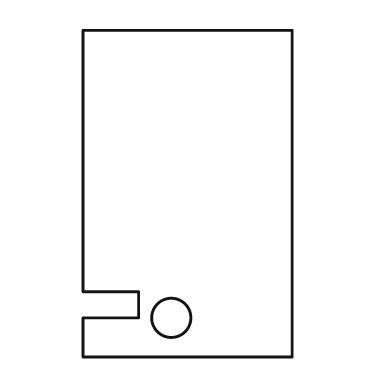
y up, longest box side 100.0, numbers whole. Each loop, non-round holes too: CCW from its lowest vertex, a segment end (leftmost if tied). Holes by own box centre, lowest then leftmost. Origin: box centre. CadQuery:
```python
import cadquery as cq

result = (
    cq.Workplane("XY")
    .moveTo(-32.0, -50.0)
    .lineTo(32.0, -50.0)
    .lineTo(32.0, 50.0)
    .lineTo(-32.0, 50.0)
    .lineTo(-32.0, -30.0)
    .lineTo(-15.0, -30.0)
    .lineTo(-15.0, -38.0)
    .lineTo(-32.0, -38.0)
    .close()
    .moveTo(-5.0, -38.0)
    .circle(6.0)
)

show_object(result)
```